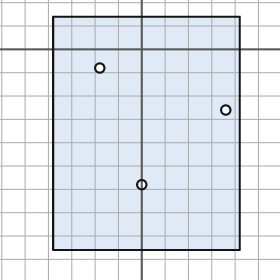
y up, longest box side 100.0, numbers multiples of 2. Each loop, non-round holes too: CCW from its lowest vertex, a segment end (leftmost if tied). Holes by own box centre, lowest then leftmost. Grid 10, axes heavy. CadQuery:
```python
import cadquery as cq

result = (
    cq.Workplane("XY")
    .moveTo(-38.0, -86.0)
    .lineTo(42.0, -86.0)
    .lineTo(42.0, 14.0)
    .lineTo(-38.0, 14.0)
    .close()
    .moveTo(0.0, -58.0)
    .circle(2.0)
    .moveTo(36.0, -26.0)
    .circle(2.0)
    .moveTo(-18.0, -8.0)
    .circle(2.0)
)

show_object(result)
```